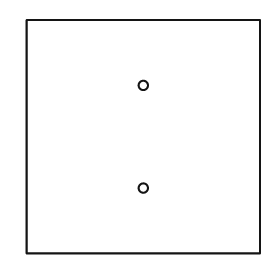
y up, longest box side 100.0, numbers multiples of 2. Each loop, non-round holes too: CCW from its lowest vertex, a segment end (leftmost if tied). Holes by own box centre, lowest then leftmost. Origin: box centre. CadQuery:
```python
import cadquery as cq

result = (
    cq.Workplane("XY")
    .moveTo(-50.0, -50.0)
    .lineTo(50.0, -50.0)
    .lineTo(50.0, 50.0)
    .lineTo(-50.0, 50.0)
    .close()
    .moveTo(0.0, -22.0)
    .circle(2.0)
    .moveTo(0.0, 22.0)
    .circle(2.0)
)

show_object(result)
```